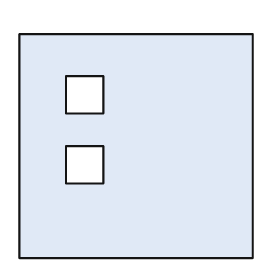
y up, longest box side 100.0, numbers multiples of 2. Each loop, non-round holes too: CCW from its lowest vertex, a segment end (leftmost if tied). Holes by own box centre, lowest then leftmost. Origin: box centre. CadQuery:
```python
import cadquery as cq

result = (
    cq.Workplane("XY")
    .moveTo(-50.0, -48.0)
    .lineTo(50.0, -48.0)
    .lineTo(50.0, 48.0)
    .lineTo(-50.0, 48.0)
    .close()
    .moveTo(-30.0, -16.0)
    .lineTo(-14.0, -16.0)
    .lineTo(-14.0, 0.0)
    .lineTo(-30.0, 0.0)
    .close()
    .moveTo(-30.0, 14.0)
    .lineTo(-14.0, 14.0)
    .lineTo(-14.0, 30.0)
    .lineTo(-30.0, 30.0)
    .close()
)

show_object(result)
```